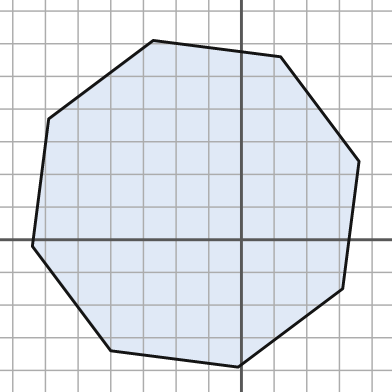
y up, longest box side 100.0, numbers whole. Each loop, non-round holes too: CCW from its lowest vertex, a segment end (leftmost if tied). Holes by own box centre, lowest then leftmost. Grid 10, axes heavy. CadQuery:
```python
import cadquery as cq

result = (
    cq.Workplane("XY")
    .moveTo(-1.0, -39.0)
    .lineTo(31.0, -15.0)
    .lineTo(36.0, 24.0)
    .lineTo(12.0, 56.0)
    .lineTo(-27.0, 61.0)
    .lineTo(-59.0, 37.0)
    .lineTo(-64.0, -2.0)
    .lineTo(-40.0, -34.0)
    .close()
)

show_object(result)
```